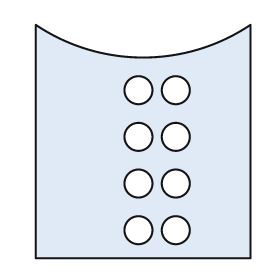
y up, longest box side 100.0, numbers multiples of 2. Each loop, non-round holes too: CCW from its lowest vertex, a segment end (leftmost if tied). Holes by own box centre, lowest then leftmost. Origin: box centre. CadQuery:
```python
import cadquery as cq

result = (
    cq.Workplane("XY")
    .moveTo(-46.0, -50.0)
    .lineTo(46.0, -50.0)
    .lineTo(46.0, 50.0)
    .threePointArc((0.0, 36.0), (-46.0, 50.0))
    .close()
    .moveTo(-2.0, -38.0)
    .circle(6.0)
    .moveTo(14.0, -38.0)
    .circle(6.0)
    .moveTo(-2.0, -18.0)
    .circle(6.0)
    .moveTo(14.0, -18.0)
    .circle(6.0)
    .moveTo(-2.0, 2.0)
    .circle(6.0)
    .moveTo(14.0, 2.0)
    .circle(6.0)
    .moveTo(-2.0, 22.0)
    .circle(6.0)
    .moveTo(14.0, 22.0)
    .circle(6.0)
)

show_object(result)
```